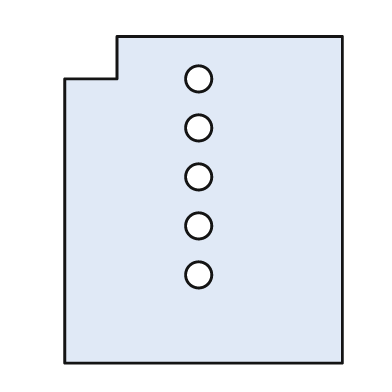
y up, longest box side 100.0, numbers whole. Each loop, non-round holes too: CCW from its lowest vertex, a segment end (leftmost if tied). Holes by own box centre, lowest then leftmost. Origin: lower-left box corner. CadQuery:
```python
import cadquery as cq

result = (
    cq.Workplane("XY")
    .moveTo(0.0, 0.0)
    .lineTo(85.0, 0.0)
    .lineTo(85.0, 100.0)
    .lineTo(16.0, 100.0)
    .lineTo(16.0, 87.0)
    .lineTo(0.0, 87.0)
    .close()
    .moveTo(41.0, 27.0)
    .circle(4.0)
    .moveTo(41.0, 42.0)
    .circle(4.0)
    .moveTo(41.0, 57.0)
    .circle(4.0)
    .moveTo(41.0, 72.0)
    .circle(4.0)
    .moveTo(41.0, 87.0)
    .circle(4.0)
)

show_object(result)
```